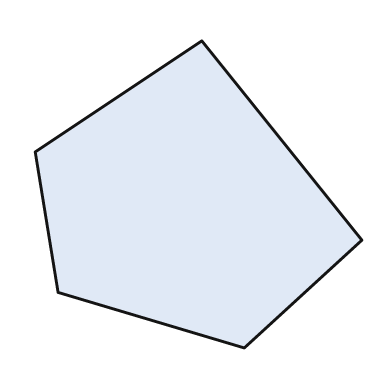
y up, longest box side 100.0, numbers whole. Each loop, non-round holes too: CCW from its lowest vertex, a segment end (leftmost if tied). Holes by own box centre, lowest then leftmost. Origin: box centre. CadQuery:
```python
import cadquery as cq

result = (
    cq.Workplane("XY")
    .moveTo(14.0, -47.0)
    .lineTo(50.0, -14.0)
    .lineTo(1.0, 47.0)
    .lineTo(-50.0, 13.0)
    .lineTo(-43.0, -30.0)
    .close()
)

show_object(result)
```